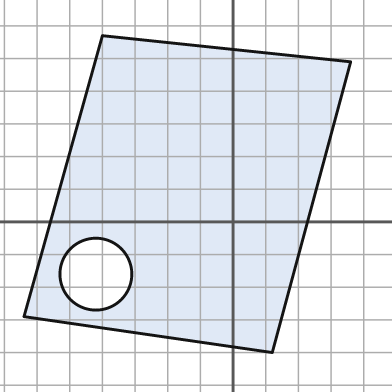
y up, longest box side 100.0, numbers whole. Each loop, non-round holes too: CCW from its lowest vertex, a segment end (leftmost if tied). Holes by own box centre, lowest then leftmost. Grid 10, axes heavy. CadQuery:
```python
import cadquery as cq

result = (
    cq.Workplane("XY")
    .moveTo(12.0, -40.0)
    .lineTo(36.0, 49.0)
    .lineTo(-40.0, 57.0)
    .lineTo(-64.0, -29.0)
    .close()
    .moveTo(-42.0, -16.0)
    .circle(11.0)
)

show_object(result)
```